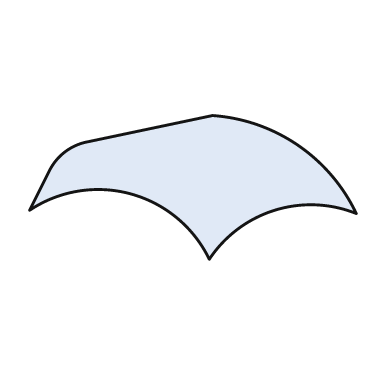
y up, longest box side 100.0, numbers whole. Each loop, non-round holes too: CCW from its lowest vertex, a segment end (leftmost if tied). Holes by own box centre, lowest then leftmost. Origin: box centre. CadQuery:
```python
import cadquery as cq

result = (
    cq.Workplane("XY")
    .moveTo(5.0, -22.0)
    .threePointArc((25.0, -7.0), (50.0, -8.0))
    .threePointArc((32.0, 13.0), (6.0, 22.0))
    .lineTo(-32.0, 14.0)
    .threePointArc((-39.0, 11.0), (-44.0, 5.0))
    .lineTo(-50.0, -7.0)
    .threePointArc((-19.0, -2.0), (5.0, -22.0))
    .close()
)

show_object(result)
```